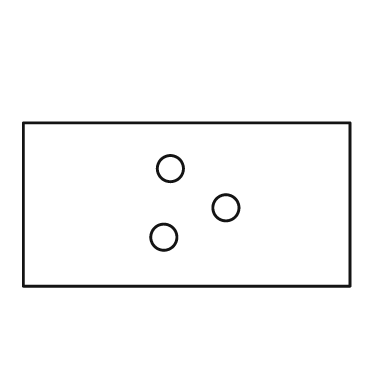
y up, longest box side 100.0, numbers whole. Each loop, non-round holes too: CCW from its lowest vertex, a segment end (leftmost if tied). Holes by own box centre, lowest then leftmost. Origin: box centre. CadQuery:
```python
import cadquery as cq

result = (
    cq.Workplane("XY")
    .moveTo(-50.0, -25.0)
    .lineTo(50.0, -25.0)
    .lineTo(50.0, 25.0)
    .lineTo(-50.0, 25.0)
    .close()
    .moveTo(-7.0, -10.0)
    .circle(4.0)
    .moveTo(12.0, -1.0)
    .circle(4.0)
    .moveTo(-5.0, 11.0)
    .circle(4.0)
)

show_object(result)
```